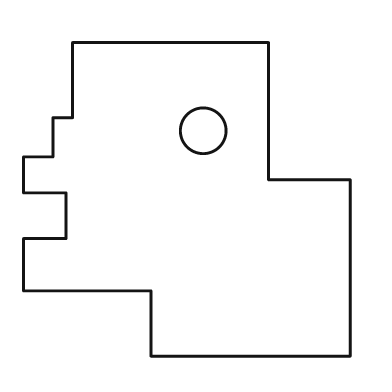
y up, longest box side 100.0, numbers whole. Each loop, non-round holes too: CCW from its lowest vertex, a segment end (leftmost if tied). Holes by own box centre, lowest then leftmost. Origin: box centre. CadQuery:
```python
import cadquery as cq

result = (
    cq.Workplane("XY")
    .moveTo(-11.0, -48.0)
    .lineTo(50.0, -48.0)
    .lineTo(50.0, 6.0)
    .lineTo(25.0, 6.0)
    .lineTo(25.0, 48.0)
    .lineTo(-35.0, 48.0)
    .lineTo(-35.0, 25.0)
    .lineTo(-41.0, 25.0)
    .lineTo(-41.0, 13.0)
    .lineTo(-50.0, 13.0)
    .lineTo(-50.0, 2.0)
    .lineTo(-37.0, 2.0)
    .lineTo(-37.0, -12.0)
    .lineTo(-50.0, -12.0)
    .lineTo(-50.0, -28.0)
    .lineTo(-11.0, -28.0)
    .close()
    .moveTo(5.0, 21.0)
    .circle(7.0)
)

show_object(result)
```